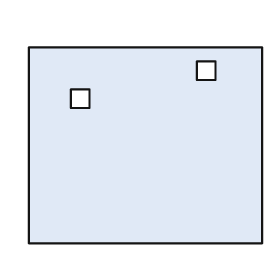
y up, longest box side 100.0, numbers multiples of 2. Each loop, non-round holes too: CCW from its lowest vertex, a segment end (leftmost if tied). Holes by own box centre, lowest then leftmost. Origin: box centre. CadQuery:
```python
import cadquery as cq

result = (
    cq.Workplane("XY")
    .moveTo(-50.0, -42.0)
    .lineTo(50.0, -42.0)
    .lineTo(50.0, 42.0)
    .lineTo(-50.0, 42.0)
    .close()
    .moveTo(-32.0, 16.0)
    .lineTo(-24.0, 16.0)
    .lineTo(-24.0, 24.0)
    .lineTo(-32.0, 24.0)
    .close()
    .moveTo(22.0, 28.0)
    .lineTo(30.0, 28.0)
    .lineTo(30.0, 36.0)
    .lineTo(22.0, 36.0)
    .close()
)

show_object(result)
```